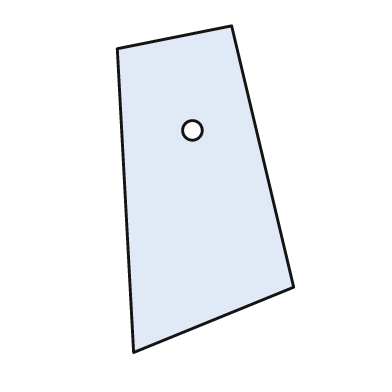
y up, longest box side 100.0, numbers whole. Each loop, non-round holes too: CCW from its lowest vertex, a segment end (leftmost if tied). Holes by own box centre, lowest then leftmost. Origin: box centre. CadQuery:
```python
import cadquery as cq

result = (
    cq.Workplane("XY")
    .moveTo(-22.0, -50.0)
    .lineTo(27.0, -30.0)
    .lineTo(8.0, 50.0)
    .lineTo(-27.0, 43.0)
    .close()
    .moveTo(-4.0, 18.0)
    .circle(3.0)
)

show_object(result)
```